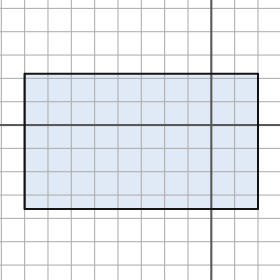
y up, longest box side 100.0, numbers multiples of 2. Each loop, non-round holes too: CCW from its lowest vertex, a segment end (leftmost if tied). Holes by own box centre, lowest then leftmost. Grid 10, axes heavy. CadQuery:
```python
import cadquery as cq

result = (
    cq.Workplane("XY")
    .moveTo(-80.0, -36.0)
    .lineTo(20.0, -36.0)
    .lineTo(20.0, 22.0)
    .lineTo(-80.0, 22.0)
    .close()
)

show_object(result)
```